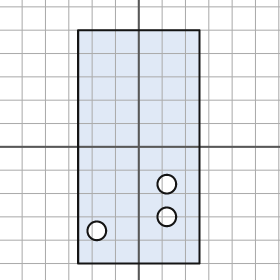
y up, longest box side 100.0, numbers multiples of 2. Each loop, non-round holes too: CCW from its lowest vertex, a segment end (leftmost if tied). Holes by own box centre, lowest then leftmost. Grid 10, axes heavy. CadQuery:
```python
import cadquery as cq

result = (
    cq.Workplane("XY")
    .moveTo(-26.0, -50.0)
    .lineTo(26.0, -50.0)
    .lineTo(26.0, 50.0)
    .lineTo(-26.0, 50.0)
    .close()
    .moveTo(-18.0, -36.0)
    .circle(4.0)
    .moveTo(12.0, -30.0)
    .circle(4.0)
    .moveTo(12.0, -16.0)
    .circle(4.0)
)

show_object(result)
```